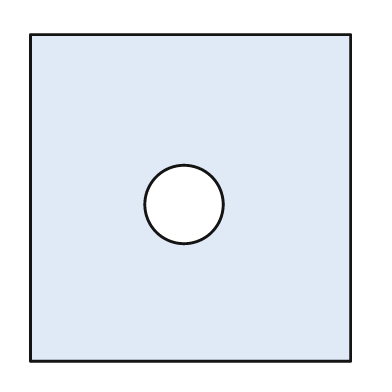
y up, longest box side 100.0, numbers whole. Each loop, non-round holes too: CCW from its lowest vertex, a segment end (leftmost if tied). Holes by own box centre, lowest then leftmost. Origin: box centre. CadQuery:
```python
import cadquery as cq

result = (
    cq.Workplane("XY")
    .moveTo(-49.0, -50.0)
    .lineTo(49.0, -50.0)
    .lineTo(49.0, 50.0)
    .lineTo(-49.0, 50.0)
    .close()
    .moveTo(-2.0, -2.0)
    .circle(12.0)
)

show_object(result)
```